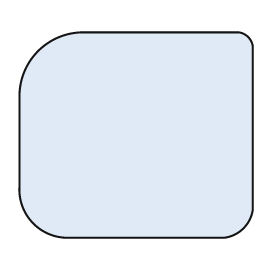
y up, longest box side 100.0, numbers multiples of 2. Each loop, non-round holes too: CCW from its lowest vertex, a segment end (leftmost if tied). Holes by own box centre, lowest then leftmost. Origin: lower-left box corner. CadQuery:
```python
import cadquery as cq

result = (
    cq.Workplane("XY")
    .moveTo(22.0, 0.0)
    .lineTo(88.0, 0.0)
    .threePointArc((96.0, 4.0), (100.0, 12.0))
    .lineTo(100.0, 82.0)
    .threePointArc((98.0, 86.0), (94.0, 88.0))
    .lineTo(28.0, 88.0)
    .threePointArc((8.0, 80.0), (0.0, 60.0))
    .lineTo(0.0, 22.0)
    .threePointArc((6.0, 6.0), (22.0, 0.0))
    .close()
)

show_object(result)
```